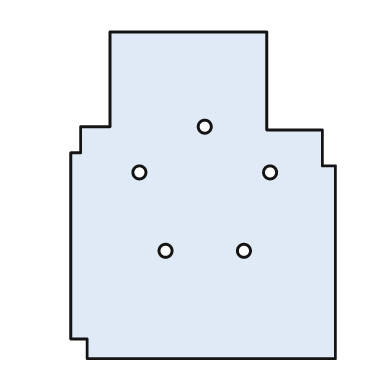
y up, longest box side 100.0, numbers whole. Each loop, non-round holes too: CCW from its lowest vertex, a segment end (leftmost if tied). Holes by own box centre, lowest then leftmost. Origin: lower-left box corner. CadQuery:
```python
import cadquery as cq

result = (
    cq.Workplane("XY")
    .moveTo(5.0, 0.0)
    .lineTo(81.0, 0.0)
    .lineTo(81.0, 59.0)
    .lineTo(77.0, 59.0)
    .lineTo(77.0, 70.0)
    .lineTo(60.0, 70.0)
    .lineTo(60.0, 100.0)
    .lineTo(12.0, 100.0)
    .lineTo(12.0, 71.0)
    .lineTo(3.0, 71.0)
    .lineTo(3.0, 63.0)
    .lineTo(0.0, 63.0)
    .lineTo(0.0, 6.0)
    .lineTo(5.0, 6.0)
    .close()
    .moveTo(29.0, 33.0)
    .circle(2.0)
    .moveTo(53.0, 33.0)
    .circle(2.0)
    .moveTo(21.0, 57.0)
    .circle(2.0)
    .moveTo(61.0, 57.0)
    .circle(2.0)
    .moveTo(41.0, 71.0)
    .circle(2.0)
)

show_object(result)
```